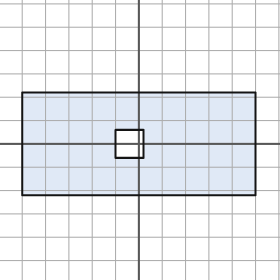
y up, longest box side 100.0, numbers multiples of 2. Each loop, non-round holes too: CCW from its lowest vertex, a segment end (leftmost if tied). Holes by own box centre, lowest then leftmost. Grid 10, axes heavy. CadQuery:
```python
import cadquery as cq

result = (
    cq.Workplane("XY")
    .moveTo(-50.0, -22.0)
    .lineTo(50.0, -22.0)
    .lineTo(50.0, 22.0)
    .lineTo(-50.0, 22.0)
    .close()
    .moveTo(-10.0, -6.0)
    .lineTo(2.0, -6.0)
    .lineTo(2.0, 6.0)
    .lineTo(-10.0, 6.0)
    .close()
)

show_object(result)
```